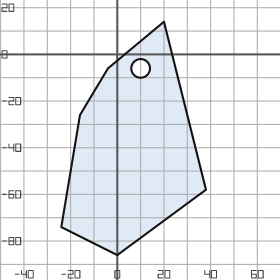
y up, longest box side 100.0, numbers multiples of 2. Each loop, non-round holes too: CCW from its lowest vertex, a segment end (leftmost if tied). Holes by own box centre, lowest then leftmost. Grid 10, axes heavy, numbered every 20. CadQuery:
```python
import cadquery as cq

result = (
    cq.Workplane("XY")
    .moveTo(0.0, -86.0)
    .lineTo(38.0, -58.0)
    .lineTo(20.0, 14.0)
    .lineTo(-4.0, -6.0)
    .lineTo(-16.0, -26.0)
    .lineTo(-24.0, -74.0)
    .close()
    .moveTo(10.0, -6.0)
    .circle(4.0)
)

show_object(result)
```